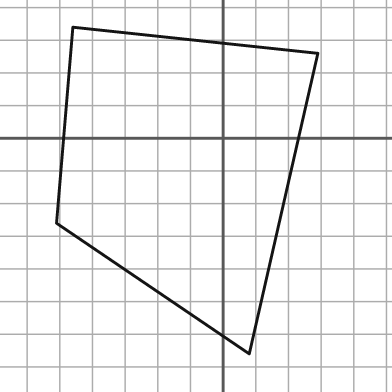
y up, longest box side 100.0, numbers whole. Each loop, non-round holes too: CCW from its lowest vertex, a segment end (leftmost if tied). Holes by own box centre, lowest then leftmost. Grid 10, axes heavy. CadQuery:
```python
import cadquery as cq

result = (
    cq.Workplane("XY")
    .moveTo(8.0, -66.0)
    .lineTo(29.0, 26.0)
    .lineTo(-46.0, 34.0)
    .lineTo(-51.0, -26.0)
    .close()
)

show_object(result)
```